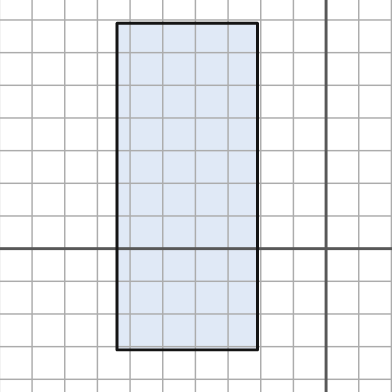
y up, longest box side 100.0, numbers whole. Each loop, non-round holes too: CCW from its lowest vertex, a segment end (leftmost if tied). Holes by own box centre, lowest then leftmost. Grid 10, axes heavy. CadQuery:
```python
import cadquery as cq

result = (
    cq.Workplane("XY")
    .moveTo(-64.0, -31.0)
    .lineTo(-21.0, -31.0)
    .lineTo(-21.0, 69.0)
    .lineTo(-64.0, 69.0)
    .close()
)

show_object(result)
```